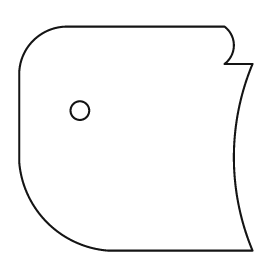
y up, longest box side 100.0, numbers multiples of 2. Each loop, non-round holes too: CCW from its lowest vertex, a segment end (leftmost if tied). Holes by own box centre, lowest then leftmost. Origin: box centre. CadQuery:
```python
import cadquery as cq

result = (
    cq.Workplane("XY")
    .moveTo(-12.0, -48.0)
    .lineTo(50.0, -48.0)
    .threePointArc((42.0, -8.0), (50.0, 32.0))
    .lineTo(38.0, 32.0)
    .threePointArc((42.0, 40.0), (38.0, 48.0))
    .lineTo(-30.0, 48.0)
    .threePointArc((-44.0, 42.0), (-50.0, 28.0))
    .lineTo(-50.0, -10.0)
    .threePointArc((-38.0, -36.0), (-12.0, -48.0))
    .close()
    .moveTo(-24.0, 12.0)
    .circle(4.0)
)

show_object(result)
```